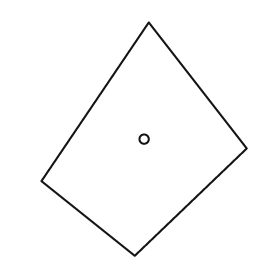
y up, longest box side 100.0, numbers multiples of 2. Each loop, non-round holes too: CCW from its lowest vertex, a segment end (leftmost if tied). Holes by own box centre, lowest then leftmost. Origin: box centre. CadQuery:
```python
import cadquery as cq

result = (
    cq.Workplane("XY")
    .moveTo(-4.0, -50.0)
    .lineTo(44.0, -4.0)
    .lineTo(2.0, 50.0)
    .lineTo(-44.0, -18.0)
    .close()
    .moveTo(0.0, 0.0)
    .circle(2.0)
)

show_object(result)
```